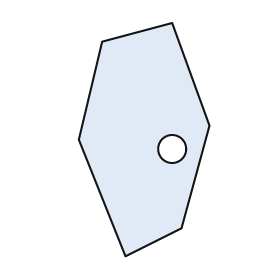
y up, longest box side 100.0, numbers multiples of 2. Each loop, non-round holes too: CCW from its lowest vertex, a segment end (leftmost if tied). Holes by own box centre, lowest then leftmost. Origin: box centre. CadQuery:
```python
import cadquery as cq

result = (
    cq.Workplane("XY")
    .moveTo(-8.0, -50.0)
    .lineTo(16.0, -38.0)
    .lineTo(28.0, 6.0)
    .lineTo(12.0, 50.0)
    .lineTo(-18.0, 42.0)
    .lineTo(-28.0, 0.0)
    .close()
    .moveTo(12.0, -4.0)
    .circle(6.0)
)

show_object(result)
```